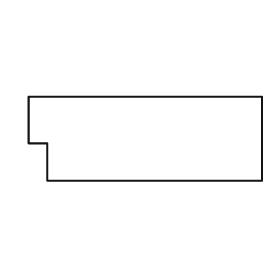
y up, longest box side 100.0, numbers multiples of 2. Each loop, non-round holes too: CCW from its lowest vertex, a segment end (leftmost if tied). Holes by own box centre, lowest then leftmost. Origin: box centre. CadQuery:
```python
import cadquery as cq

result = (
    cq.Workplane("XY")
    .moveTo(-42.0, -18.0)
    .lineTo(50.0, -18.0)
    .lineTo(50.0, 18.0)
    .lineTo(-50.0, 18.0)
    .lineTo(-50.0, -2.0)
    .lineTo(-42.0, -2.0)
    .close()
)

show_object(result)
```